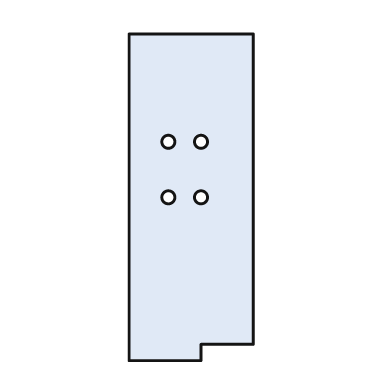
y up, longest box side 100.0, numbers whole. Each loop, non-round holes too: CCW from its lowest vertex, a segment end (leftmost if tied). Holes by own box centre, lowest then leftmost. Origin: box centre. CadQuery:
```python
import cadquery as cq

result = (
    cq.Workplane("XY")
    .moveTo(-19.0, -50.0)
    .lineTo(3.0, -50.0)
    .lineTo(3.0, -45.0)
    .lineTo(19.0, -45.0)
    .lineTo(19.0, 50.0)
    .lineTo(-19.0, 50.0)
    .close()
    .moveTo(-7.0, 0.0)
    .circle(2.0)
    .moveTo(3.0, 0.0)
    .circle(2.0)
    .moveTo(-7.0, 17.0)
    .circle(2.0)
    .moveTo(3.0, 17.0)
    .circle(2.0)
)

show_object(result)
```